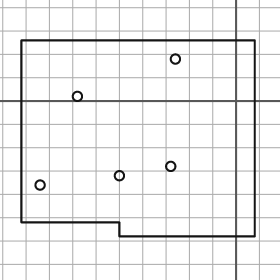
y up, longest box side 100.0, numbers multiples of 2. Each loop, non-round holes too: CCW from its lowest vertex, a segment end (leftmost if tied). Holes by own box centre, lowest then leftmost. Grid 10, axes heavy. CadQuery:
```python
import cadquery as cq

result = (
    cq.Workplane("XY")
    .moveTo(-50.0, -58.0)
    .lineTo(8.0, -58.0)
    .lineTo(8.0, 26.0)
    .lineTo(-92.0, 26.0)
    .lineTo(-92.0, -52.0)
    .lineTo(-50.0, -52.0)
    .close()
    .moveTo(-84.0, -36.0)
    .circle(2.0)
    .moveTo(-50.0, -32.0)
    .circle(2.0)
    .moveTo(-28.0, -28.0)
    .circle(2.0)
    .moveTo(-68.0, 2.0)
    .circle(2.0)
    .moveTo(-26.0, 18.0)
    .circle(2.0)
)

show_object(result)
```